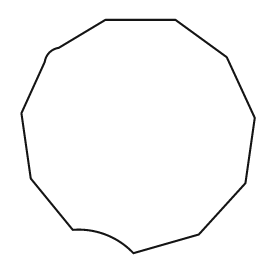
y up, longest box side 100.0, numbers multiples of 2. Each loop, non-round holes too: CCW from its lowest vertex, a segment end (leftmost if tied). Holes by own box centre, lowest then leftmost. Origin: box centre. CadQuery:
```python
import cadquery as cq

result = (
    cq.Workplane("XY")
    .moveTo(-2.0, -50.0)
    .lineTo(26.0, -42.0)
    .lineTo(46.0, -20.0)
    .lineTo(50.0, 8.0)
    .lineTo(38.0, 34.0)
    .lineTo(16.0, 50.0)
    .lineTo(-14.0, 50.0)
    .lineTo(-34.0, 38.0)
    .threePointArc((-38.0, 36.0), (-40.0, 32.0))
    .lineTo(-50.0, 10.0)
    .lineTo(-46.0, -18.0)
    .lineTo(-28.0, -40.0)
    .threePointArc((-14.0, -42.0), (-2.0, -50.0))
    .close()
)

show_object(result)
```